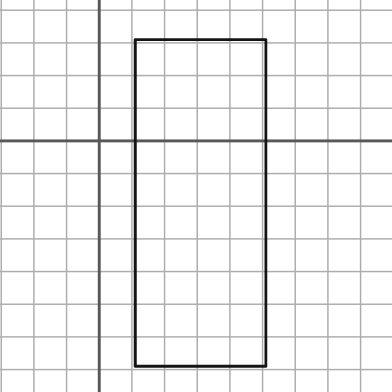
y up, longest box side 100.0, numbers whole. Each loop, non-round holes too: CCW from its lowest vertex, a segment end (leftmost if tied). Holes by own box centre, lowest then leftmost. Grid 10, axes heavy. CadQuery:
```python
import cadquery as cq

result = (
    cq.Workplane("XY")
    .moveTo(11.0, -69.0)
    .lineTo(51.0, -69.0)
    .lineTo(51.0, 31.0)
    .lineTo(11.0, 31.0)
    .close()
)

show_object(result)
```